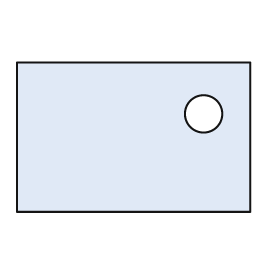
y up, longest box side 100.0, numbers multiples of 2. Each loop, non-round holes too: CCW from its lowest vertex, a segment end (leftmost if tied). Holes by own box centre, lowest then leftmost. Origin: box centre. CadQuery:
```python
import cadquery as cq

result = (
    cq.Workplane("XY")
    .moveTo(-50.0, -32.0)
    .lineTo(50.0, -32.0)
    .lineTo(50.0, 32.0)
    .lineTo(-50.0, 32.0)
    .close()
    .moveTo(30.0, 10.0)
    .circle(8.0)
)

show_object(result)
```